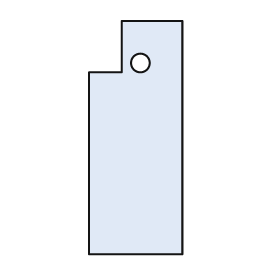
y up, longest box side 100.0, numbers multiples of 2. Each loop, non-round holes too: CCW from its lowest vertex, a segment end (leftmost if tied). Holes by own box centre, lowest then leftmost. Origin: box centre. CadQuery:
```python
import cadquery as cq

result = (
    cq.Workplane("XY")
    .moveTo(-20.0, -50.0)
    .lineTo(20.0, -50.0)
    .lineTo(20.0, 50.0)
    .lineTo(-6.0, 50.0)
    .lineTo(-6.0, 28.0)
    .lineTo(-20.0, 28.0)
    .close()
    .moveTo(2.0, 32.0)
    .circle(4.0)
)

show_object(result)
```